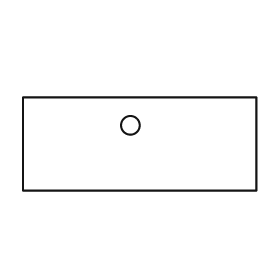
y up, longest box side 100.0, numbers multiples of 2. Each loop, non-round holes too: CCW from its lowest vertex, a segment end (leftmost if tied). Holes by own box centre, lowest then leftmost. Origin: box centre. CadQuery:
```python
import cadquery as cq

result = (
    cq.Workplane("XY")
    .moveTo(-50.0, -20.0)
    .lineTo(50.0, -20.0)
    .lineTo(50.0, 20.0)
    .lineTo(-50.0, 20.0)
    .close()
    .moveTo(-4.0, 8.0)
    .circle(4.0)
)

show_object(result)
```